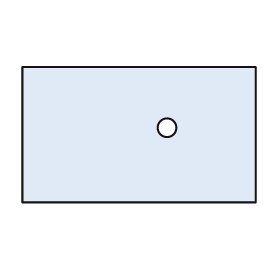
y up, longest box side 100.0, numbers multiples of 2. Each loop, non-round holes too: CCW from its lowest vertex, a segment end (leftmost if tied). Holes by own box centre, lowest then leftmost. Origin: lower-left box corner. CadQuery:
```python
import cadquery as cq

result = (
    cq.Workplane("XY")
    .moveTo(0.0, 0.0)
    .lineTo(100.0, 0.0)
    .lineTo(100.0, 58.0)
    .lineTo(0.0, 58.0)
    .close()
    .moveTo(62.0, 32.0)
    .circle(4.0)
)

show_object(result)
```